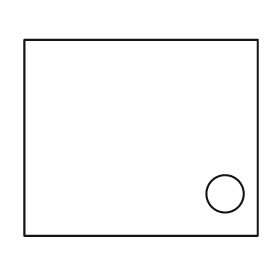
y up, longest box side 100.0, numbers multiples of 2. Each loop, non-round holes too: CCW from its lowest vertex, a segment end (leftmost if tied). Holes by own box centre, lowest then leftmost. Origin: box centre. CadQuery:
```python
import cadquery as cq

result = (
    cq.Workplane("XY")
    .moveTo(-50.0, -42.0)
    .lineTo(50.0, -42.0)
    .lineTo(50.0, 42.0)
    .lineTo(-50.0, 42.0)
    .close()
    .moveTo(36.0, -24.0)
    .circle(8.0)
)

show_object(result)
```